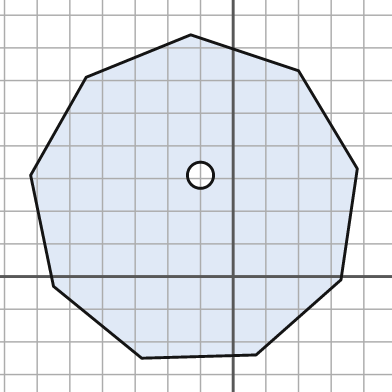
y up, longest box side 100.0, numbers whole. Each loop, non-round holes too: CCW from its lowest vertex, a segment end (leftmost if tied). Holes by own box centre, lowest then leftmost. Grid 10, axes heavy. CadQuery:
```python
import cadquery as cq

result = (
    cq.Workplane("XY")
    .moveTo(-28.0, -25.0)
    .lineTo(7.0, -24.0)
    .lineTo(33.0, -1.0)
    .lineTo(38.0, 33.0)
    .lineTo(20.0, 63.0)
    .lineTo(-13.0, 74.0)
    .lineTo(-45.0, 61.0)
    .lineTo(-62.0, 31.0)
    .lineTo(-55.0, -3.0)
    .close()
    .moveTo(-10.0, 31.0)
    .circle(4.0)
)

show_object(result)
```